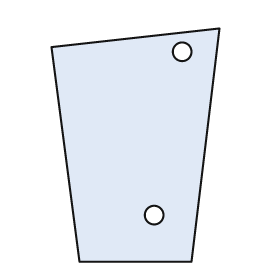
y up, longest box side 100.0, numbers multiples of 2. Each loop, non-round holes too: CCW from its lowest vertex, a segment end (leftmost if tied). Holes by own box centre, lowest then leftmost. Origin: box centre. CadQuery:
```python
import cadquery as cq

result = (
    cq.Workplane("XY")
    .moveTo(-24.0, -50.0)
    .lineTo(24.0, -50.0)
    .lineTo(36.0, 50.0)
    .lineTo(-36.0, 42.0)
    .close()
    .moveTo(8.0, -30.0)
    .circle(4.0)
    .moveTo(20.0, 40.0)
    .circle(4.0)
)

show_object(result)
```